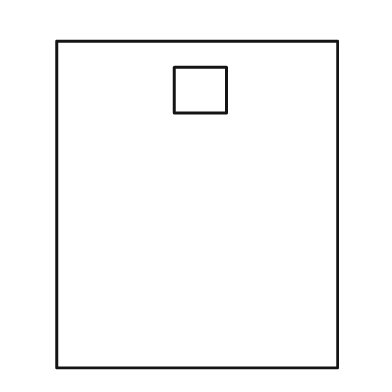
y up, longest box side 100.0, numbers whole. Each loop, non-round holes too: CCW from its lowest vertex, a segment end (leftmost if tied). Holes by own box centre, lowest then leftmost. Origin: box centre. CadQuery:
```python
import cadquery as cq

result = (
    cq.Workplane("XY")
    .moveTo(-43.0, -50.0)
    .lineTo(43.0, -50.0)
    .lineTo(43.0, 50.0)
    .lineTo(-43.0, 50.0)
    .close()
    .moveTo(-7.0, 28.0)
    .lineTo(9.0, 28.0)
    .lineTo(9.0, 42.0)
    .lineTo(-7.0, 42.0)
    .close()
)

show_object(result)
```